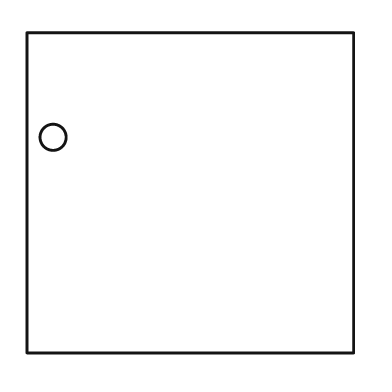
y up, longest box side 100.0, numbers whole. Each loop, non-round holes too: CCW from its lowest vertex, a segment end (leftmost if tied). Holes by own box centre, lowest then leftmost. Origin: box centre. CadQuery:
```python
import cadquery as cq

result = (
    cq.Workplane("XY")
    .moveTo(-50.0, -49.0)
    .lineTo(50.0, -49.0)
    .lineTo(50.0, 49.0)
    .lineTo(-50.0, 49.0)
    .close()
    .moveTo(-42.0, 17.0)
    .circle(4.0)
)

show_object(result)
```